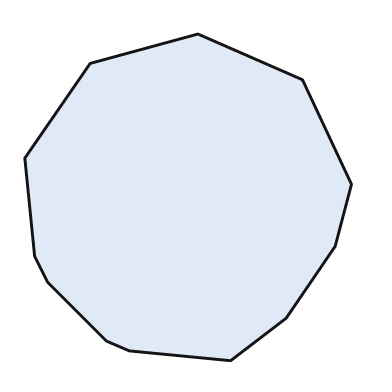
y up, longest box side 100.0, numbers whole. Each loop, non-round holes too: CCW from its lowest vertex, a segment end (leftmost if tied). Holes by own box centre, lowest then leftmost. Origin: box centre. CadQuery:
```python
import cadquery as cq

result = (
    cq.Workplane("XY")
    .moveTo(13.0, -50.0)
    .lineTo(30.0, -37.0)
    .lineTo(45.0, -15.0)
    .lineTo(50.0, 4.0)
    .lineTo(35.0, 36.0)
    .lineTo(3.0, 50.0)
    .lineTo(-30.0, 41.0)
    .lineTo(-50.0, 12.0)
    .lineTo(-47.0, -18.0)
    .lineTo(-43.0, -26.0)
    .lineTo(-25.0, -44.0)
    .lineTo(-18.0, -47.0)
    .close()
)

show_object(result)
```